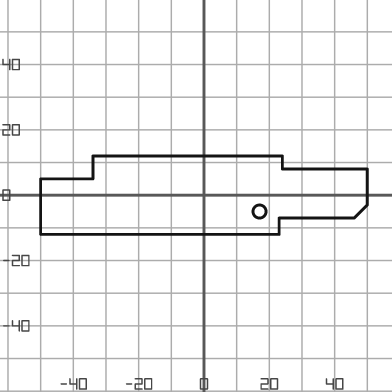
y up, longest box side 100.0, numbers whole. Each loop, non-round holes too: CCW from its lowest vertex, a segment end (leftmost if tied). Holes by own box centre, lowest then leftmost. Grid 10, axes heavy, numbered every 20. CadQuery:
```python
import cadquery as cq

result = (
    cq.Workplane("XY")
    .moveTo(-50.0, -12.0)
    .lineTo(23.0, -12.0)
    .lineTo(23.0, -7.0)
    .lineTo(46.0, -7.0)
    .lineTo(50.0, -3.0)
    .lineTo(50.0, 8.0)
    .lineTo(24.0, 8.0)
    .lineTo(24.0, 12.0)
    .lineTo(-34.0, 12.0)
    .lineTo(-34.0, 5.0)
    .lineTo(-50.0, 5.0)
    .close()
    .moveTo(17.0, -5.0)
    .circle(2.0)
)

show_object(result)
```